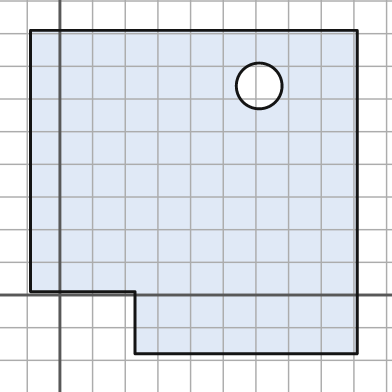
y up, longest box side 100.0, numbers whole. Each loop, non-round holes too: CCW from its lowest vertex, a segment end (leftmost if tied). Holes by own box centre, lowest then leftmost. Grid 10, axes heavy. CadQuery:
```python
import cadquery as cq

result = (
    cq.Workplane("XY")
    .moveTo(23.0, -18.0)
    .lineTo(91.0, -18.0)
    .lineTo(91.0, 81.0)
    .lineTo(-9.0, 81.0)
    .lineTo(-9.0, 1.0)
    .lineTo(23.0, 1.0)
    .close()
    .moveTo(61.0, 64.0)
    .circle(7.0)
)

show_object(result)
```